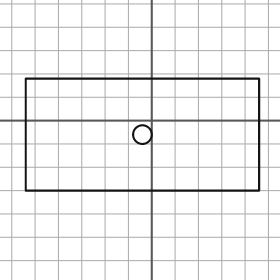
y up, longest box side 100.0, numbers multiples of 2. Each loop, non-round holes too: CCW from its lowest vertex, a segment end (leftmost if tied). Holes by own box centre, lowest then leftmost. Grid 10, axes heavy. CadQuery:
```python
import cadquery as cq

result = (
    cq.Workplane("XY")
    .moveTo(-54.0, -30.0)
    .lineTo(46.0, -30.0)
    .lineTo(46.0, 18.0)
    .lineTo(-54.0, 18.0)
    .close()
    .moveTo(-4.0, -6.0)
    .circle(4.0)
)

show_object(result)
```